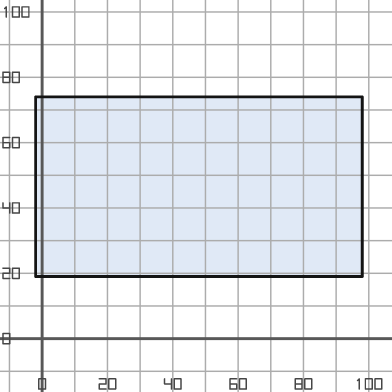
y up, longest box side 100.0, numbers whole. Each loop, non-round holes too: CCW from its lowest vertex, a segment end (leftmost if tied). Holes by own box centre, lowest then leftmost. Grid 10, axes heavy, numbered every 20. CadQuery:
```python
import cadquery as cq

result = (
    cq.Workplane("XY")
    .moveTo(-2.0, 19.0)
    .lineTo(98.0, 19.0)
    .lineTo(98.0, 74.0)
    .lineTo(-2.0, 74.0)
    .close()
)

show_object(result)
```